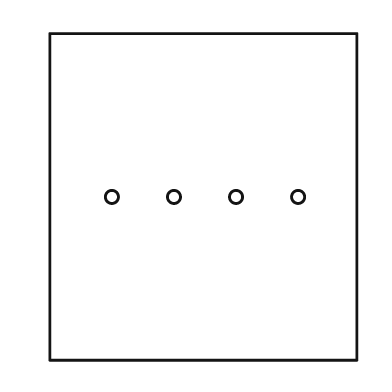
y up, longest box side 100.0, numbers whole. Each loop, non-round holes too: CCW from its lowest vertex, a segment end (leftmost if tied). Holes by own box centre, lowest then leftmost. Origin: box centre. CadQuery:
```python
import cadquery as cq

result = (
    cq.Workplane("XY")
    .moveTo(-47.0, -50.0)
    .lineTo(47.0, -50.0)
    .lineTo(47.0, 50.0)
    .lineTo(-47.0, 50.0)
    .close()
    .moveTo(-28.0, 0.0)
    .circle(2.0)
    .moveTo(-9.0, 0.0)
    .circle(2.0)
    .moveTo(10.0, 0.0)
    .circle(2.0)
    .moveTo(29.0, 0.0)
    .circle(2.0)
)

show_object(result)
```